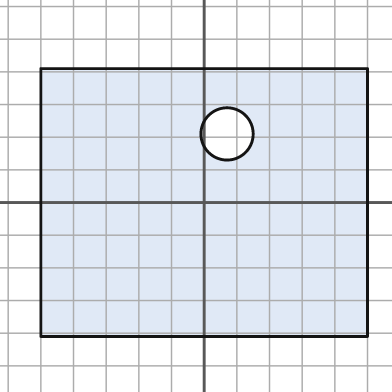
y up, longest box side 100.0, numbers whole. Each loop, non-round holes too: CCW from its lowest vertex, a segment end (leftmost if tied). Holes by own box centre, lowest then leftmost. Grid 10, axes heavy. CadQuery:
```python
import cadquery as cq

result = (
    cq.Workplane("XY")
    .moveTo(-50.0, -41.0)
    .lineTo(50.0, -41.0)
    .lineTo(50.0, 41.0)
    .lineTo(-50.0, 41.0)
    .close()
    .moveTo(7.0, 21.0)
    .circle(8.0)
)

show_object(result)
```